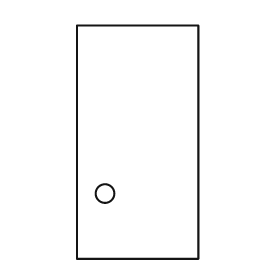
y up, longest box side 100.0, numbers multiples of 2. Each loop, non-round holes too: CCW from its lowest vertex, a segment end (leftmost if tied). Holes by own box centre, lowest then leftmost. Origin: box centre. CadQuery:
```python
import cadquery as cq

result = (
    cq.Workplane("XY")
    .moveTo(-26.0, -50.0)
    .lineTo(26.0, -50.0)
    .lineTo(26.0, 50.0)
    .lineTo(-26.0, 50.0)
    .close()
    .moveTo(-14.0, -22.0)
    .circle(4.0)
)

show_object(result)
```